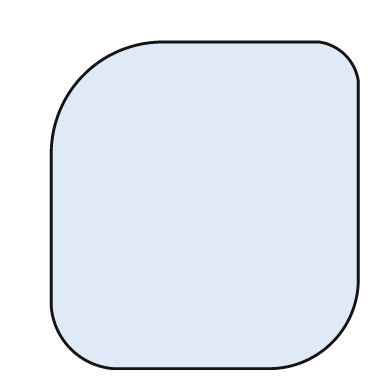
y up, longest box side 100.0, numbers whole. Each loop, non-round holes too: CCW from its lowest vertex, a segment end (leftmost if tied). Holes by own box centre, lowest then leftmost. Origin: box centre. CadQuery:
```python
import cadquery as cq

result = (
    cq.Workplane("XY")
    .moveTo(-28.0, -50.0)
    .lineTo(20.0, -50.0)
    .threePointArc((39.0, -42.0), (47.0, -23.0))
    .lineTo(47.0, 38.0)
    .threePointArc((43.0, 46.0), (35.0, 50.0))
    .lineTo(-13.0, 50.0)
    .threePointArc((-37.0, 40.0), (-47.0, 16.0))
    .lineTo(-47.0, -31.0)
    .threePointArc((-41.0, -44.0), (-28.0, -50.0))
    .close()
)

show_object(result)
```